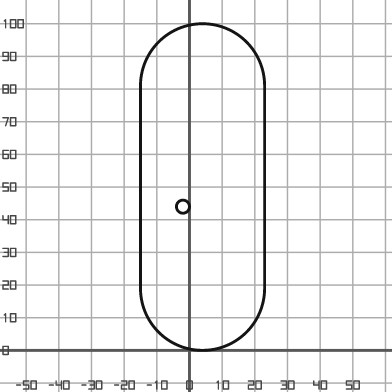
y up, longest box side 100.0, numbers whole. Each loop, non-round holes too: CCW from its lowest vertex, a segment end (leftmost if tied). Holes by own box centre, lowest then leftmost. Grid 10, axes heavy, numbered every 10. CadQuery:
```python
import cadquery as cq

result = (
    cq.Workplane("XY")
    .moveTo(-15.0, 19.0)
    .threePointArc((4.0, 0.0), (23.0, 19.0))
    .lineTo(23.0, 81.0)
    .threePointArc((4.0, 100.0), (-15.0, 81.0))
    .close()
    .moveTo(-2.0, 44.0)
    .circle(2.0)
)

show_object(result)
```